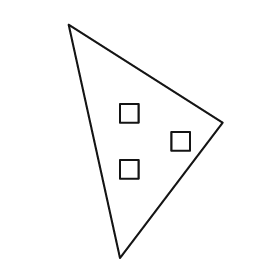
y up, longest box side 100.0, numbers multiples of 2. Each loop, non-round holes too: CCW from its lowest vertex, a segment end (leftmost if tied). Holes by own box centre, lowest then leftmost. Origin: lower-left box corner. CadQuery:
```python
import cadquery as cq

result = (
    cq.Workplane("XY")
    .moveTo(22.0, 0.0)
    .lineTo(66.0, 58.0)
    .lineTo(0.0, 100.0)
    .close()
    .moveTo(22.0, 34.0)
    .lineTo(30.0, 34.0)
    .lineTo(30.0, 42.0)
    .lineTo(22.0, 42.0)
    .close()
    .moveTo(44.0, 46.0)
    .lineTo(52.0, 46.0)
    .lineTo(52.0, 54.0)
    .lineTo(44.0, 54.0)
    .close()
    .moveTo(22.0, 58.0)
    .lineTo(30.0, 58.0)
    .lineTo(30.0, 66.0)
    .lineTo(22.0, 66.0)
    .close()
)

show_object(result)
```